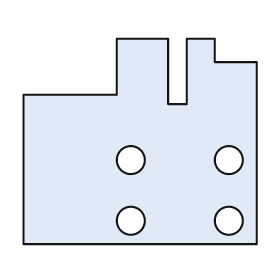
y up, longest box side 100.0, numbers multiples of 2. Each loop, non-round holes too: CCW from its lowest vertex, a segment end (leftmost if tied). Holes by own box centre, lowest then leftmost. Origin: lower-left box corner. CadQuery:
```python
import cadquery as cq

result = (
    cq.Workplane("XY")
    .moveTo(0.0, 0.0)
    .lineTo(100.0, 0.0)
    .lineTo(100.0, 78.0)
    .lineTo(82.0, 78.0)
    .lineTo(82.0, 88.0)
    .lineTo(70.0, 88.0)
    .lineTo(70.0, 60.0)
    .lineTo(62.0, 60.0)
    .lineTo(62.0, 88.0)
    .lineTo(40.0, 88.0)
    .lineTo(40.0, 64.0)
    .lineTo(0.0, 64.0)
    .close()
    .moveTo(46.0, 10.0)
    .circle(6.0)
    .moveTo(88.0, 10.0)
    .circle(6.0)
    .moveTo(46.0, 36.0)
    .circle(6.0)
    .moveTo(88.0, 36.0)
    .circle(6.0)
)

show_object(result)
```